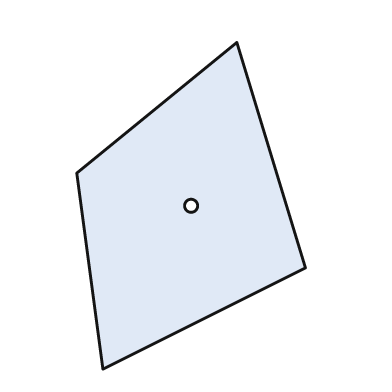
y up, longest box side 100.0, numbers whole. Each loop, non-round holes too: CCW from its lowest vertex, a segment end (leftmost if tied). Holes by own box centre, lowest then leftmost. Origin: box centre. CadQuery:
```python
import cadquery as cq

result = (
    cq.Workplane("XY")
    .moveTo(-27.0, -50.0)
    .lineTo(35.0, -19.0)
    .lineTo(14.0, 50.0)
    .lineTo(-35.0, 10.0)
    .close()
    .moveTo(0.0, 0.0)
    .circle(2.0)
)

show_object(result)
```